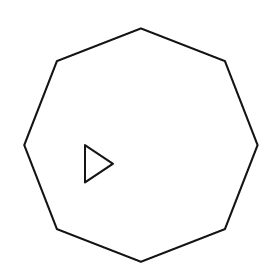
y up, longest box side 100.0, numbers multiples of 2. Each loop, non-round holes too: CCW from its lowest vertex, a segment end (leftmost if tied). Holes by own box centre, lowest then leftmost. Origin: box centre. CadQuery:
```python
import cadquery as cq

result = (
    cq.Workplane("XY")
    .moveTo(0.0, -50.0)
    .lineTo(36.0, -36.0)
    .lineTo(50.0, 0.0)
    .lineTo(36.0, 36.0)
    .lineTo(0.0, 50.0)
    .lineTo(-36.0, 36.0)
    .lineTo(-50.0, 0.0)
    .lineTo(-36.0, -36.0)
    .close()
    .moveTo(-24.0, -16.0)
    .lineTo(-12.0, -8.0)
    .lineTo(-24.0, 0.0)
    .close()
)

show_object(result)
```